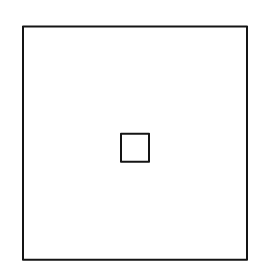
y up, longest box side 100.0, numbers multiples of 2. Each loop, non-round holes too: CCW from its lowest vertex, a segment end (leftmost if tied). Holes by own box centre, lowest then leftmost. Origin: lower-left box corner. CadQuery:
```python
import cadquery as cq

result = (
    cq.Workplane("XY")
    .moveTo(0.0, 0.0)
    .lineTo(96.0, 0.0)
    .lineTo(96.0, 100.0)
    .lineTo(0.0, 100.0)
    .close()
    .moveTo(42.0, 42.0)
    .lineTo(54.0, 42.0)
    .lineTo(54.0, 54.0)
    .lineTo(42.0, 54.0)
    .close()
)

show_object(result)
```